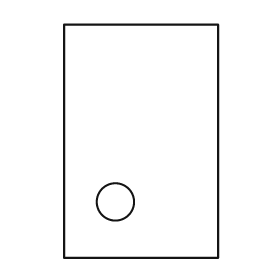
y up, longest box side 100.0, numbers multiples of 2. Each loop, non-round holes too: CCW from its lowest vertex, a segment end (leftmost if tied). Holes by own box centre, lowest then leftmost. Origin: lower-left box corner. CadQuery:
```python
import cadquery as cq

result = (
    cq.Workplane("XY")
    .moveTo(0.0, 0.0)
    .lineTo(66.0, 0.0)
    .lineTo(66.0, 100.0)
    .lineTo(0.0, 100.0)
    .close()
    .moveTo(22.0, 24.0)
    .circle(8.0)
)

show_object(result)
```